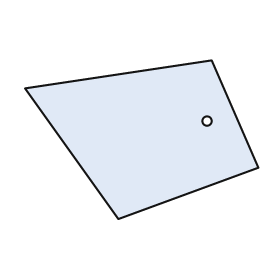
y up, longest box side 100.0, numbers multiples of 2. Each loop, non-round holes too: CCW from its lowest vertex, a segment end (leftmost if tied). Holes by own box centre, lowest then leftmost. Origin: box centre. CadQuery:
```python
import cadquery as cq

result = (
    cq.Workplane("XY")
    .moveTo(-10.0, -34.0)
    .lineTo(50.0, -12.0)
    .lineTo(30.0, 34.0)
    .lineTo(-50.0, 22.0)
    .close()
    .moveTo(28.0, 8.0)
    .circle(2.0)
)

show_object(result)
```